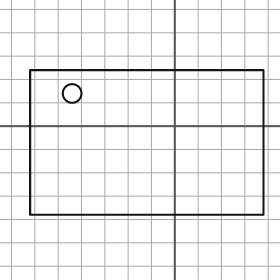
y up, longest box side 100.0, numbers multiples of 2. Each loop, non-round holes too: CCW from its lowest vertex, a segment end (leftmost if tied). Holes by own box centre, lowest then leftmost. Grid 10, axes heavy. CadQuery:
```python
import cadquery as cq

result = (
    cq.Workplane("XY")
    .moveTo(-62.0, -38.0)
    .lineTo(38.0, -38.0)
    .lineTo(38.0, 24.0)
    .lineTo(-62.0, 24.0)
    .close()
    .moveTo(-44.0, 14.0)
    .circle(4.0)
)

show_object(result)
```